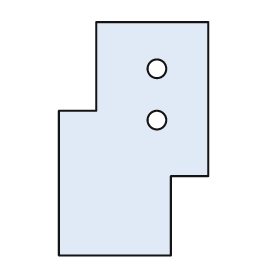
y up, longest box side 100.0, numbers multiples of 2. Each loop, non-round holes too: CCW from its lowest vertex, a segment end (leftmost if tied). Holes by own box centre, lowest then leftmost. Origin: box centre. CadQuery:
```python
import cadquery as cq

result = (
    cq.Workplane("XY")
    .moveTo(-32.0, -50.0)
    .lineTo(16.0, -50.0)
    .lineTo(16.0, -16.0)
    .lineTo(32.0, -16.0)
    .lineTo(32.0, 50.0)
    .lineTo(-16.0, 50.0)
    .lineTo(-16.0, 12.0)
    .lineTo(-32.0, 12.0)
    .close()
    .moveTo(10.0, 8.0)
    .circle(4.0)
    .moveTo(10.0, 30.0)
    .circle(4.0)
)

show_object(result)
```